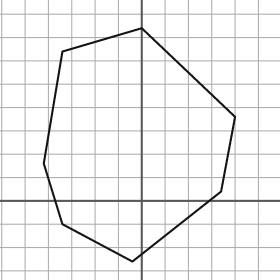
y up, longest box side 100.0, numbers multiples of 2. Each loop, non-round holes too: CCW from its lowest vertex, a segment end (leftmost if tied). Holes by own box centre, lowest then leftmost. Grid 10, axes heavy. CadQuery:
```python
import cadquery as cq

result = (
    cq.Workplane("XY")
    .moveTo(-4.0, -26.0)
    .lineTo(34.0, 4.0)
    .lineTo(40.0, 36.0)
    .lineTo(0.0, 74.0)
    .lineTo(-34.0, 64.0)
    .lineTo(-42.0, 16.0)
    .lineTo(-34.0, -10.0)
    .close()
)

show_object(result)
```